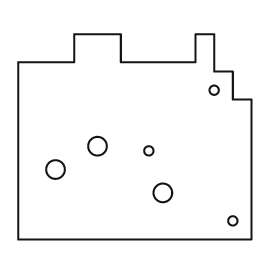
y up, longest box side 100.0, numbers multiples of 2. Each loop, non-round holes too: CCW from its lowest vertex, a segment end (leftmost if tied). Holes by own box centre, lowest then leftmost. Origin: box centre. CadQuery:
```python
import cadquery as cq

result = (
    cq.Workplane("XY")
    .moveTo(-50.0, -44.0)
    .lineTo(50.0, -44.0)
    .lineTo(50.0, 16.0)
    .lineTo(42.0, 16.0)
    .lineTo(42.0, 28.0)
    .lineTo(34.0, 28.0)
    .lineTo(34.0, 44.0)
    .lineTo(26.0, 44.0)
    .lineTo(26.0, 32.0)
    .lineTo(-6.0, 32.0)
    .lineTo(-6.0, 44.0)
    .lineTo(-26.0, 44.0)
    .lineTo(-26.0, 32.0)
    .lineTo(-50.0, 32.0)
    .close()
    .moveTo(42.0, -36.0)
    .circle(2.0)
    .moveTo(12.0, -24.0)
    .circle(4.0)
    .moveTo(-34.0, -14.0)
    .circle(4.0)
    .moveTo(6.0, -6.0)
    .circle(2.0)
    .moveTo(-16.0, -4.0)
    .circle(4.0)
    .moveTo(34.0, 20.0)
    .circle(2.0)
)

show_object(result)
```